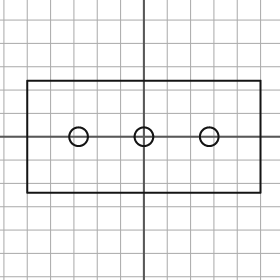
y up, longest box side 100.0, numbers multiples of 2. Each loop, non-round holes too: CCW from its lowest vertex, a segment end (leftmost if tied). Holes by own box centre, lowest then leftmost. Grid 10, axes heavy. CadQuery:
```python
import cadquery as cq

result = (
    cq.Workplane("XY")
    .moveTo(-50.0, -24.0)
    .lineTo(50.0, -24.0)
    .lineTo(50.0, 24.0)
    .lineTo(-50.0, 24.0)
    .close()
    .moveTo(-28.0, 0.0)
    .circle(4.0)
    .moveTo(0.0, 0.0)
    .circle(4.0)
    .moveTo(28.0, 0.0)
    .circle(4.0)
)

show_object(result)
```